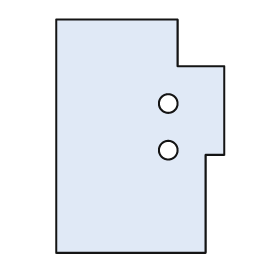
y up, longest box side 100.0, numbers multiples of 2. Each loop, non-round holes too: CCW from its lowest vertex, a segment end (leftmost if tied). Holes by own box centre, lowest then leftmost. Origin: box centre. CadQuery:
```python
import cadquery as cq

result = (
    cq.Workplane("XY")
    .moveTo(-36.0, -50.0)
    .lineTo(28.0, -50.0)
    .lineTo(28.0, -8.0)
    .lineTo(36.0, -8.0)
    .lineTo(36.0, 30.0)
    .lineTo(16.0, 30.0)
    .lineTo(16.0, 50.0)
    .lineTo(-36.0, 50.0)
    .close()
    .moveTo(12.0, -6.0)
    .circle(4.0)
    .moveTo(12.0, 14.0)
    .circle(4.0)
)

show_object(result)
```